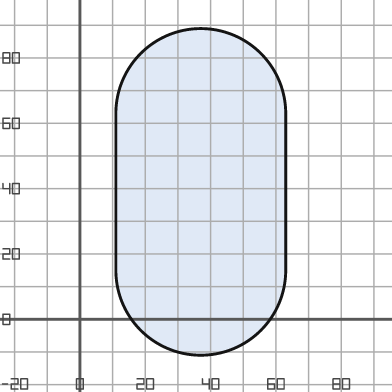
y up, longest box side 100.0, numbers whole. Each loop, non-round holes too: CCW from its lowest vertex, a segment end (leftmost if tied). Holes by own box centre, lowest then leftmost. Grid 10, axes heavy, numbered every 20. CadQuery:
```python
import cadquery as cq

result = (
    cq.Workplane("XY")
    .moveTo(11.0, 15.0)
    .threePointArc((37.0, -11.0), (63.0, 15.0))
    .lineTo(63.0, 63.0)
    .threePointArc((37.0, 89.0), (11.0, 63.0))
    .close()
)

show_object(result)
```